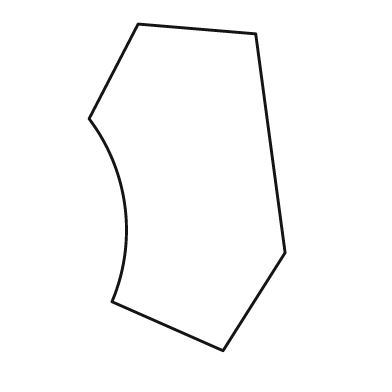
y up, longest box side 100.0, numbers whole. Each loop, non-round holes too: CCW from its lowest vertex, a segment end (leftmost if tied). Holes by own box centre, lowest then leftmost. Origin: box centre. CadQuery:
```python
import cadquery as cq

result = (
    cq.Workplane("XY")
    .moveTo(11.0, -50.0)
    .lineTo(30.0, -20.0)
    .lineTo(21.0, 47.0)
    .lineTo(-15.0, 50.0)
    .lineTo(-30.0, 21.0)
    .threePointArc((-19.0, -6.0), (-23.0, -35.0))
    .close()
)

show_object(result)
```